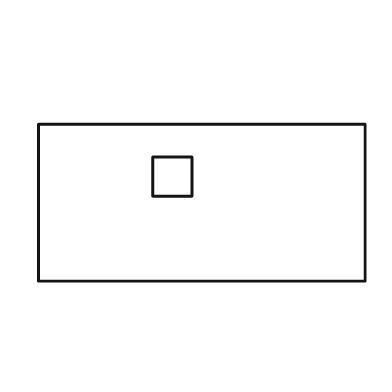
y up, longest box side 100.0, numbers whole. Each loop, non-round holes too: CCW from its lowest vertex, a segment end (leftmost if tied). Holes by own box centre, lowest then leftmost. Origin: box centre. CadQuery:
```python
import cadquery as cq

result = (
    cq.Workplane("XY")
    .moveTo(-50.0, -24.0)
    .lineTo(50.0, -24.0)
    .lineTo(50.0, 24.0)
    .lineTo(-50.0, 24.0)
    .close()
    .moveTo(-15.0, 2.0)
    .lineTo(-3.0, 2.0)
    .lineTo(-3.0, 14.0)
    .lineTo(-15.0, 14.0)
    .close()
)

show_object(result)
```